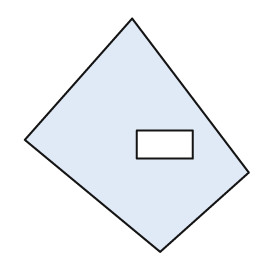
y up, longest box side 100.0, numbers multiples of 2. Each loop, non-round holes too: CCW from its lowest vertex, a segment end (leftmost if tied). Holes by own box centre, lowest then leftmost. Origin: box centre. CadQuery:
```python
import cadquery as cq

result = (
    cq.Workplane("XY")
    .moveTo(10.0, -50.0)
    .lineTo(48.0, -16.0)
    .lineTo(-2.0, 50.0)
    .lineTo(-48.0, -2.0)
    .close()
    .moveTo(0.0, -10.0)
    .lineTo(24.0, -10.0)
    .lineTo(24.0, 2.0)
    .lineTo(0.0, 2.0)
    .close()
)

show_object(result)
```